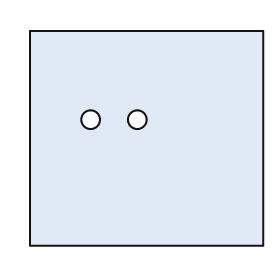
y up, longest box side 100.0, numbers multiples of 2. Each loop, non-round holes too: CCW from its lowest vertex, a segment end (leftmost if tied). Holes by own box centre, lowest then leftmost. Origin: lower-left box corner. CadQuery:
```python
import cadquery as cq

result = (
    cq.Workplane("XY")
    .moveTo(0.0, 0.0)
    .lineTo(100.0, 0.0)
    .lineTo(100.0, 92.0)
    .lineTo(0.0, 92.0)
    .close()
    .moveTo(26.0, 54.0)
    .circle(4.0)
    .moveTo(46.0, 54.0)
    .circle(4.0)
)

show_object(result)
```